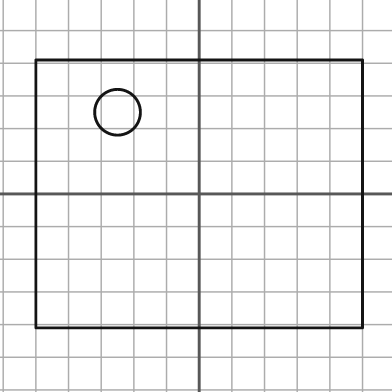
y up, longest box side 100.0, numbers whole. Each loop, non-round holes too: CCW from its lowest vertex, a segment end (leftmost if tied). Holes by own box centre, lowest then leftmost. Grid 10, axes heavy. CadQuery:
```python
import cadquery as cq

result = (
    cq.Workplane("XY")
    .moveTo(-50.0, -41.0)
    .lineTo(50.0, -41.0)
    .lineTo(50.0, 41.0)
    .lineTo(-50.0, 41.0)
    .close()
    .moveTo(-25.0, 25.0)
    .circle(7.0)
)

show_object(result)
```